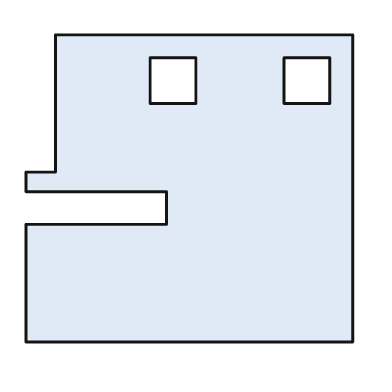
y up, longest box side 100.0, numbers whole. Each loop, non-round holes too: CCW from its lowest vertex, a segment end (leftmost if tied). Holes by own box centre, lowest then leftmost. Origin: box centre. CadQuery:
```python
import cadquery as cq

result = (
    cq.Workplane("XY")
    .moveTo(-50.0, -47.0)
    .lineTo(50.0, -47.0)
    .lineTo(50.0, 47.0)
    .lineTo(-41.0, 47.0)
    .lineTo(-41.0, 5.0)
    .lineTo(-50.0, 5.0)
    .lineTo(-50.0, -1.0)
    .lineTo(-7.0, -1.0)
    .lineTo(-7.0, -11.0)
    .lineTo(-50.0, -11.0)
    .close()
    .moveTo(-12.0, 26.0)
    .lineTo(2.0, 26.0)
    .lineTo(2.0, 40.0)
    .lineTo(-12.0, 40.0)
    .close()
    .moveTo(29.0, 26.0)
    .lineTo(43.0, 26.0)
    .lineTo(43.0, 40.0)
    .lineTo(29.0, 40.0)
    .close()
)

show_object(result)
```